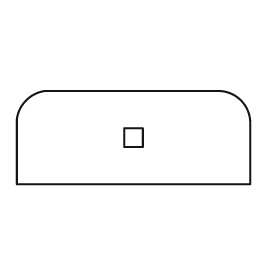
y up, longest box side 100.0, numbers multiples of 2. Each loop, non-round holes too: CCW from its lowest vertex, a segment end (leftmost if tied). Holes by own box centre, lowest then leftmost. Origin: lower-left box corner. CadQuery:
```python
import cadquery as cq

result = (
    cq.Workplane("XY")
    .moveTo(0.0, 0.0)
    .lineTo(100.0, 0.0)
    .lineTo(100.0, 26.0)
    .threePointArc((96.0, 36.0), (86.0, 40.0))
    .lineTo(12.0, 40.0)
    .threePointArc((4.0, 36.0), (0.0, 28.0))
    .close()
    .moveTo(46.0, 16.0)
    .lineTo(54.0, 16.0)
    .lineTo(54.0, 24.0)
    .lineTo(46.0, 24.0)
    .close()
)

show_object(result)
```